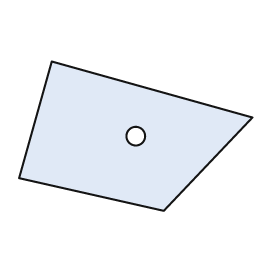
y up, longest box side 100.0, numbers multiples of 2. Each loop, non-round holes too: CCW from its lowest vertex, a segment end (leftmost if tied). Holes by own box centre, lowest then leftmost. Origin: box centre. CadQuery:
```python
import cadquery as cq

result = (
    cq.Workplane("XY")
    .moveTo(12.0, -32.0)
    .lineTo(50.0, 8.0)
    .lineTo(-36.0, 32.0)
    .lineTo(-50.0, -18.0)
    .close()
    .moveTo(0.0, 0.0)
    .circle(4.0)
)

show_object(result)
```